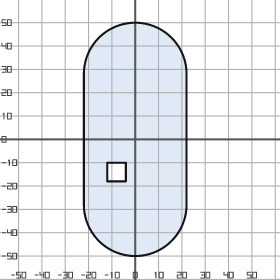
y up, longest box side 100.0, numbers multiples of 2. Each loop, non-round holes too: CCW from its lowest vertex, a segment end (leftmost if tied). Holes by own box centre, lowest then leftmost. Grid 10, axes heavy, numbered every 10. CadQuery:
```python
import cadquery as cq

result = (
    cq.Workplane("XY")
    .moveTo(-22.0, -28.0)
    .threePointArc((0.0, -50.0), (22.0, -28.0))
    .lineTo(22.0, 28.0)
    .threePointArc((0.0, 50.0), (-22.0, 28.0))
    .close()
    .moveTo(-12.0, -18.0)
    .lineTo(-4.0, -18.0)
    .lineTo(-4.0, -10.0)
    .lineTo(-12.0, -10.0)
    .close()
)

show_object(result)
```